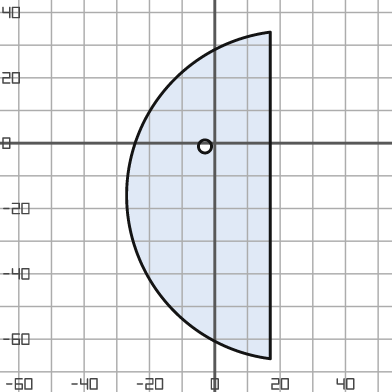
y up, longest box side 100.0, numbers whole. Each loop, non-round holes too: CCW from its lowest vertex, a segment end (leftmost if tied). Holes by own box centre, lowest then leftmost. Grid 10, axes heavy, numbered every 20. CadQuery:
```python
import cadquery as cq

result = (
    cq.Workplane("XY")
    .moveTo(17.0, -66.0)
    .lineTo(17.0, 34.0)
    .threePointArc((-27.0, -16.0), (17.0, -66.0))
    .close()
    .moveTo(-3.0, -1.0)
    .circle(2.0)
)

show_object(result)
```